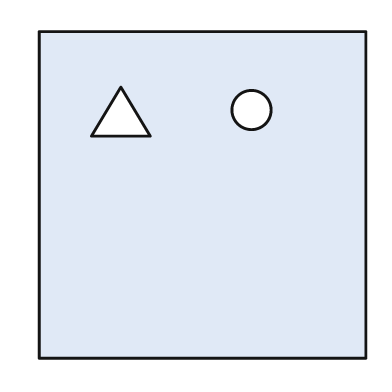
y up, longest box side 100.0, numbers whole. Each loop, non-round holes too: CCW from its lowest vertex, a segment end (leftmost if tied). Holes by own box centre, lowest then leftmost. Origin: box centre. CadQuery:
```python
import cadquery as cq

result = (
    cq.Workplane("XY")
    .moveTo(-50.0, -50.0)
    .lineTo(50.0, -50.0)
    .lineTo(50.0, 50.0)
    .lineTo(-50.0, 50.0)
    .close()
    .moveTo(-34.0, 18.0)
    .lineTo(-16.0, 18.0)
    .lineTo(-25.0, 33.0)
    .close()
    .moveTo(15.0, 26.0)
    .circle(6.0)
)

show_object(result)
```